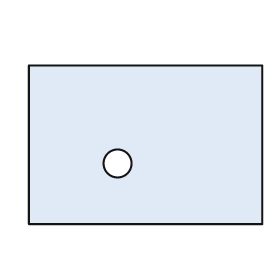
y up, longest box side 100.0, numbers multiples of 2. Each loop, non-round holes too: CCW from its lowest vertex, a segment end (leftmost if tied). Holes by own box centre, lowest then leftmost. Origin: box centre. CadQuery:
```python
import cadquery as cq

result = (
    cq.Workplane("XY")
    .moveTo(-50.0, -34.0)
    .lineTo(50.0, -34.0)
    .lineTo(50.0, 34.0)
    .lineTo(-50.0, 34.0)
    .close()
    .moveTo(-12.0, -8.0)
    .circle(6.0)
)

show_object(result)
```